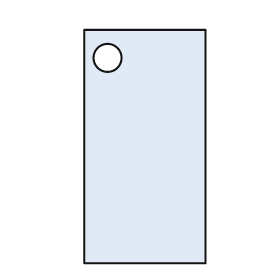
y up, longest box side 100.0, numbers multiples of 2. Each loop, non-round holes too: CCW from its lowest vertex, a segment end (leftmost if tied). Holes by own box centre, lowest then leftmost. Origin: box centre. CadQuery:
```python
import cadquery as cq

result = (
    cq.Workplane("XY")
    .moveTo(-26.0, -50.0)
    .lineTo(26.0, -50.0)
    .lineTo(26.0, 50.0)
    .lineTo(-26.0, 50.0)
    .close()
    .moveTo(-16.0, 38.0)
    .circle(6.0)
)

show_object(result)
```